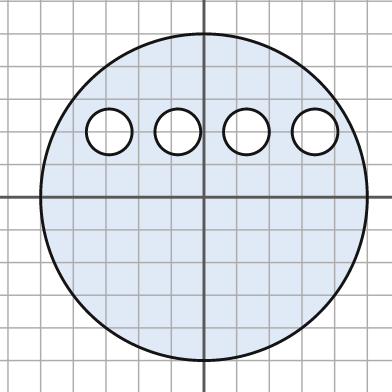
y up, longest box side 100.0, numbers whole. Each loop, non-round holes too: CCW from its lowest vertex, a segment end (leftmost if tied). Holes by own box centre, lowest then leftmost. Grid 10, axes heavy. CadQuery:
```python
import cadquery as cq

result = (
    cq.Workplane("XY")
    .moveTo(0.0, 0.0)
    .circle(50.0)
    .moveTo(-29.0, 20.0)
    .circle(7.0)
    .moveTo(-8.0, 20.0)
    .circle(7.0)
    .moveTo(13.0, 20.0)
    .circle(7.0)
    .moveTo(34.0, 20.0)
    .circle(7.0)
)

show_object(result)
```